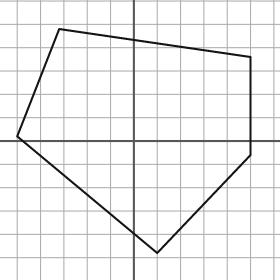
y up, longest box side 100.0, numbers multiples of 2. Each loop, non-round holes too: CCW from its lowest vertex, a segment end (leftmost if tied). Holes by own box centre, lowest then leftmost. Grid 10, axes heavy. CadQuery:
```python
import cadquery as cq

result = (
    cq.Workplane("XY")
    .moveTo(10.0, -48.0)
    .lineTo(50.0, -6.0)
    .lineTo(50.0, 36.0)
    .lineTo(-32.0, 48.0)
    .lineTo(-50.0, 2.0)
    .close()
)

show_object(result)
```